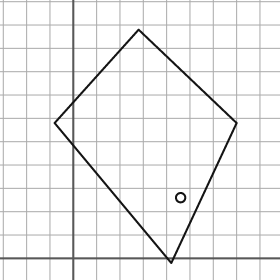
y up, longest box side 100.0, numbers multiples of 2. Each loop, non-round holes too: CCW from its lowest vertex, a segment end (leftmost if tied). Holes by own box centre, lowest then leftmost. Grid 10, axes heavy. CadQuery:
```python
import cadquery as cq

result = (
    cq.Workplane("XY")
    .moveTo(42.0, -2.0)
    .lineTo(70.0, 58.0)
    .lineTo(28.0, 98.0)
    .lineTo(-8.0, 58.0)
    .close()
    .moveTo(46.0, 26.0)
    .circle(2.0)
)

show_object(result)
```